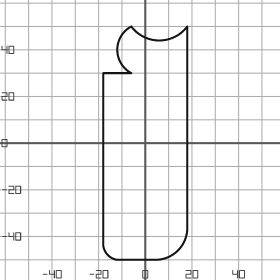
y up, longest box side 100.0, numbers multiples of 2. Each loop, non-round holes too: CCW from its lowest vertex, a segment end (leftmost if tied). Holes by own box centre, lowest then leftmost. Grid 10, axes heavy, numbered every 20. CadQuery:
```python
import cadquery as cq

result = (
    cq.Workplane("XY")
    .moveTo(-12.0, -50.0)
    .lineTo(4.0, -50.0)
    .threePointArc((14.0, -46.0), (18.0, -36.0))
    .lineTo(18.0, 50.0)
    .threePointArc((6.0, 44.0), (-6.0, 50.0))
    .threePointArc((-12.0, 40.0), (-6.0, 30.0))
    .lineTo(-18.0, 30.0)
    .lineTo(-18.0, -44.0)
    .threePointArc((-16.0, -48.0), (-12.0, -50.0))
    .close()
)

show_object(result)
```